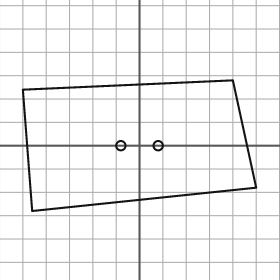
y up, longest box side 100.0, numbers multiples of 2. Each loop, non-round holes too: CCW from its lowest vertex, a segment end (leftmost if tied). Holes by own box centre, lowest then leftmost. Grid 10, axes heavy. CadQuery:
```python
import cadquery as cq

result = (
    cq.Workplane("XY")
    .moveTo(-46.0, -28.0)
    .lineTo(50.0, -18.0)
    .lineTo(40.0, 28.0)
    .lineTo(-50.0, 24.0)
    .close()
    .moveTo(-8.0, 0.0)
    .circle(2.0)
    .moveTo(8.0, 0.0)
    .circle(2.0)
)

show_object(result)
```